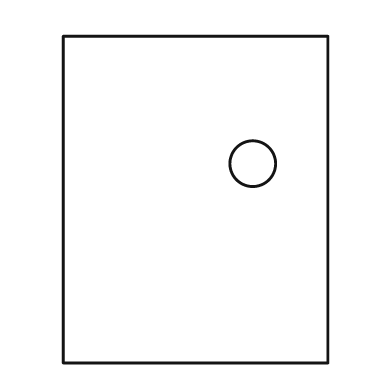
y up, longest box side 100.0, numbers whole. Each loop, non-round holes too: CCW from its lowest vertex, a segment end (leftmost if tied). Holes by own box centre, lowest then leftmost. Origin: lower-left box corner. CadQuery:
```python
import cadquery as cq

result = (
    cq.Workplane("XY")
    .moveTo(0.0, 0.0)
    .lineTo(81.0, 0.0)
    .lineTo(81.0, 100.0)
    .lineTo(0.0, 100.0)
    .close()
    .moveTo(58.0, 61.0)
    .circle(7.0)
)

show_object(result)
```